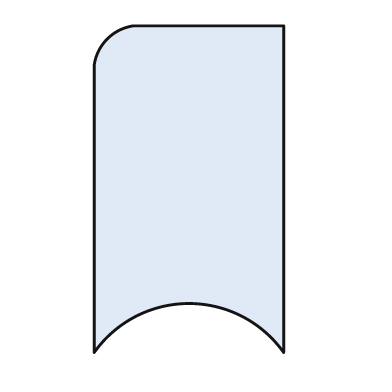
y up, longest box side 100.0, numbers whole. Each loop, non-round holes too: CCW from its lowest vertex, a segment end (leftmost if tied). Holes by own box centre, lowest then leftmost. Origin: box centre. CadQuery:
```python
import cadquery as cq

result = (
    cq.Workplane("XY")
    .moveTo(-29.0, -50.0)
    .threePointArc((0.0, -35.0), (29.0, -50.0))
    .lineTo(29.0, 50.0)
    .lineTo(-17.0, 50.0)
    .threePointArc((-25.0, 46.0), (-29.0, 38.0))
    .close()
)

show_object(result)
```